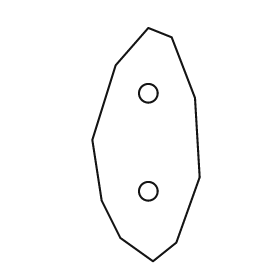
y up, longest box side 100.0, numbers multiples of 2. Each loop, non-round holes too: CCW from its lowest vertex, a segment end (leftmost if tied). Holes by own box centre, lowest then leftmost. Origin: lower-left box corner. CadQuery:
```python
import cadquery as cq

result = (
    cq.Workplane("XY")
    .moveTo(26.0, 0.0)
    .lineTo(36.0, 8.0)
    .lineTo(46.0, 36.0)
    .lineTo(44.0, 70.0)
    .lineTo(34.0, 96.0)
    .lineTo(24.0, 100.0)
    .lineTo(10.0, 84.0)
    .lineTo(0.0, 52.0)
    .lineTo(4.0, 26.0)
    .lineTo(12.0, 10.0)
    .close()
    .moveTo(24.0, 30.0)
    .circle(4.0)
    .moveTo(24.0, 72.0)
    .circle(4.0)
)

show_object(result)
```